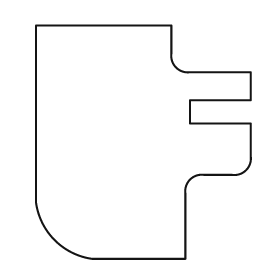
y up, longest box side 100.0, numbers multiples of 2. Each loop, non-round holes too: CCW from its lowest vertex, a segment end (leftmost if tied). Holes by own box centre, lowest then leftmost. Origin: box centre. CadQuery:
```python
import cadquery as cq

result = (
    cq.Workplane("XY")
    .moveTo(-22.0, -50.0)
    .lineTo(18.0, -50.0)
    .lineTo(18.0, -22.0)
    .threePointArc((20.0, -16.0), (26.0, -14.0))
    .lineTo(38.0, -14.0)
    .threePointArc((44.0, -12.0), (46.0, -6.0))
    .lineTo(46.0, 8.0)
    .lineTo(20.0, 8.0)
    .lineTo(20.0, 18.0)
    .lineTo(46.0, 18.0)
    .lineTo(46.0, 30.0)
    .lineTo(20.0, 30.0)
    .threePointArc((14.0, 32.0), (12.0, 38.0))
    .lineTo(12.0, 50.0)
    .lineTo(-46.0, 50.0)
    .lineTo(-46.0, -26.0)
    .threePointArc((-38.0, -42.0), (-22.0, -50.0))
    .close()
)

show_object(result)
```